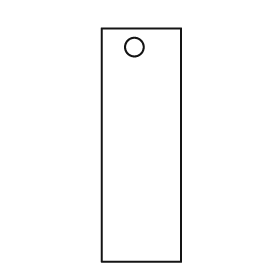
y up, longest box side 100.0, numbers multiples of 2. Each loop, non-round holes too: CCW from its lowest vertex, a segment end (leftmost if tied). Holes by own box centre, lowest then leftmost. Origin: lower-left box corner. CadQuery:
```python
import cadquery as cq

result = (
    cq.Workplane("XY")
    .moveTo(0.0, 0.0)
    .lineTo(34.0, 0.0)
    .lineTo(34.0, 100.0)
    .lineTo(0.0, 100.0)
    .close()
    .moveTo(14.0, 92.0)
    .circle(4.0)
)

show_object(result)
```